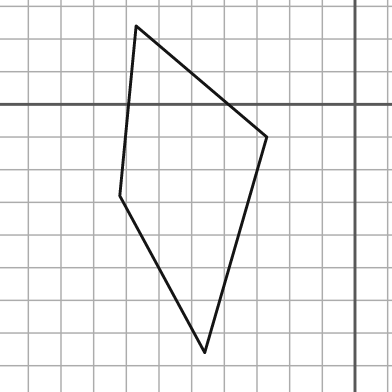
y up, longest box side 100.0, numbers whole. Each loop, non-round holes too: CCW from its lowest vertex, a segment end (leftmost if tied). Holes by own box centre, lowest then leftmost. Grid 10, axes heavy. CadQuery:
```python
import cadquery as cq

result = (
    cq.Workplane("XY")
    .moveTo(-46.0, -76.0)
    .lineTo(-27.0, -10.0)
    .lineTo(-67.0, 24.0)
    .lineTo(-72.0, -28.0)
    .close()
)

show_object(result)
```